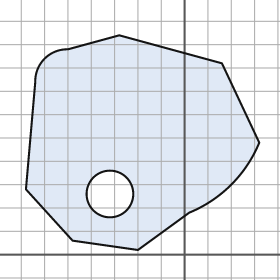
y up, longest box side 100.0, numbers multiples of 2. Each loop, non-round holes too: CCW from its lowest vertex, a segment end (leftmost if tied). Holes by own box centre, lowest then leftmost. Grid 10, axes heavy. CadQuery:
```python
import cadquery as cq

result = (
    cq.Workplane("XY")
    .moveTo(-20.0, 2.0)
    .lineTo(2.0, 18.0)
    .threePointArc((20.0, 30.0), (32.0, 48.0))
    .lineTo(16.0, 82.0)
    .lineTo(-28.0, 94.0)
    .lineTo(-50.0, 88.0)
    .threePointArc((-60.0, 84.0), (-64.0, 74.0))
    .lineTo(-68.0, 28.0)
    .lineTo(-48.0, 6.0)
    .close()
    .moveTo(-32.0, 26.0)
    .circle(10.0)
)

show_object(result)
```